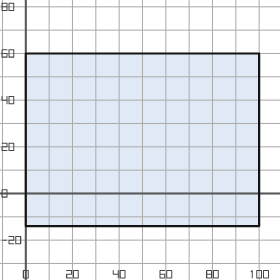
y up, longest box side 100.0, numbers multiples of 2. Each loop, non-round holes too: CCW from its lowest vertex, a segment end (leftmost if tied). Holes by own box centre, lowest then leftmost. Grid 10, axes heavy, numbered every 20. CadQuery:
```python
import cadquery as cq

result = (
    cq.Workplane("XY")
    .moveTo(0.0, -14.0)
    .lineTo(100.0, -14.0)
    .lineTo(100.0, 60.0)
    .lineTo(0.0, 60.0)
    .close()
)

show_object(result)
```